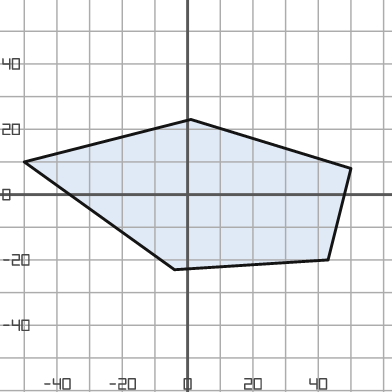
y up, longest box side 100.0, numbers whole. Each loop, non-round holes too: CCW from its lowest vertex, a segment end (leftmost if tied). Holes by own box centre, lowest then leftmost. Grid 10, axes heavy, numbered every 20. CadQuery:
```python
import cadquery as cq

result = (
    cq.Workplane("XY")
    .moveTo(-4.0, -23.0)
    .lineTo(43.0, -20.0)
    .lineTo(50.0, 8.0)
    .lineTo(1.0, 23.0)
    .lineTo(-50.0, 10.0)
    .close()
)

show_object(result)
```